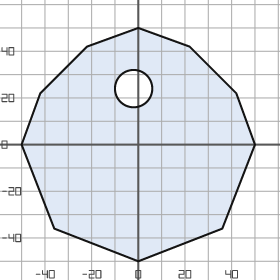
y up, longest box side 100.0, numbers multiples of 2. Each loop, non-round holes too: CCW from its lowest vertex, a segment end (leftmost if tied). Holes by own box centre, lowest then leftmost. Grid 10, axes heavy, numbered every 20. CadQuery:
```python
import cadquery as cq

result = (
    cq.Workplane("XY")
    .moveTo(0.0, -50.0)
    .lineTo(36.0, -36.0)
    .lineTo(50.0, 0.0)
    .lineTo(42.0, 22.0)
    .lineTo(22.0, 42.0)
    .lineTo(0.0, 50.0)
    .lineTo(-22.0, 42.0)
    .lineTo(-42.0, 22.0)
    .lineTo(-50.0, 0.0)
    .lineTo(-36.0, -36.0)
    .close()
    .moveTo(-2.0, 24.0)
    .circle(8.0)
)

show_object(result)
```